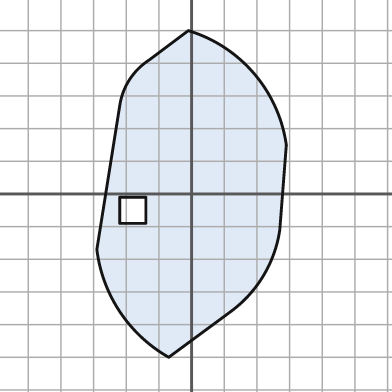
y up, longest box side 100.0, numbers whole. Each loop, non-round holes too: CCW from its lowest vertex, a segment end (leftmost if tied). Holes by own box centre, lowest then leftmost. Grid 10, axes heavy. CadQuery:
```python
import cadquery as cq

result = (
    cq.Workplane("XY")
    .moveTo(-7.0, -50.0)
    .lineTo(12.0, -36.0)
    .threePointArc((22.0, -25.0), (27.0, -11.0))
    .lineTo(29.0, 15.0)
    .threePointArc((19.0, 37.0), (-1.0, 50.0))
    .lineTo(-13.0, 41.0)
    .threePointArc((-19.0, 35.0), (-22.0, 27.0))
    .lineTo(-29.0, -17.0)
    .threePointArc((-22.0, -36.0), (-7.0, -50.0))
    .close()
    .moveTo(-22.0, -9.0)
    .lineTo(-14.0, -9.0)
    .lineTo(-14.0, -1.0)
    .lineTo(-22.0, -1.0)
    .close()
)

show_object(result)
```